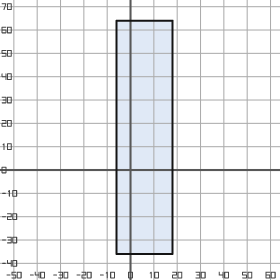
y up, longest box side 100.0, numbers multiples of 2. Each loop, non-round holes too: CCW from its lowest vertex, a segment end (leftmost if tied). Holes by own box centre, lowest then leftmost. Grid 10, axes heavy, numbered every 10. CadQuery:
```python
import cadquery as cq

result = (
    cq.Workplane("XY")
    .moveTo(-6.0, -36.0)
    .lineTo(18.0, -36.0)
    .lineTo(18.0, 64.0)
    .lineTo(-6.0, 64.0)
    .close()
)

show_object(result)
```